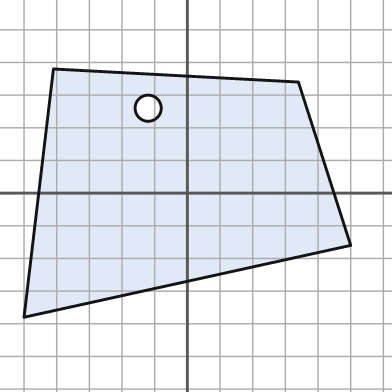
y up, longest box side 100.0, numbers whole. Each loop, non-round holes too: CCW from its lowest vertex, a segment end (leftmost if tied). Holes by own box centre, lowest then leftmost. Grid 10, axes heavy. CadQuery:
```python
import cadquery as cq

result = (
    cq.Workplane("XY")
    .moveTo(-50.0, -38.0)
    .lineTo(50.0, -16.0)
    .lineTo(34.0, 34.0)
    .lineTo(-41.0, 38.0)
    .close()
    .moveTo(-12.0, 26.0)
    .circle(4.0)
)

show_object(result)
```